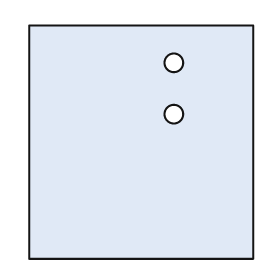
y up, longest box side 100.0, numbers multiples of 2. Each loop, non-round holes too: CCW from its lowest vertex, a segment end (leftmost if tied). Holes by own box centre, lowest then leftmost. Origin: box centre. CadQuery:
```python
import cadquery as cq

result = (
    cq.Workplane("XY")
    .moveTo(-48.0, -50.0)
    .lineTo(48.0, -50.0)
    .lineTo(48.0, 50.0)
    .lineTo(-48.0, 50.0)
    .close()
    .moveTo(14.0, 12.0)
    .circle(4.0)
    .moveTo(14.0, 34.0)
    .circle(4.0)
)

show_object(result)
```